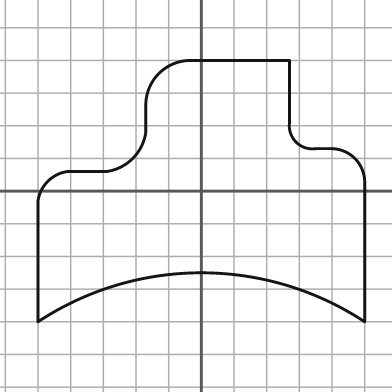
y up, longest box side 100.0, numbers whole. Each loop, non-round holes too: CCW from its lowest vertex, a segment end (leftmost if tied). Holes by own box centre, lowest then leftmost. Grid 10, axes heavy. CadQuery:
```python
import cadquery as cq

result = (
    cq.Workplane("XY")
    .moveTo(-50.0, -40.0)
    .threePointArc((0.0, -25.0), (50.0, -40.0))
    .lineTo(50.0, 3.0)
    .threePointArc((47.0, 10.0), (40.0, 13.0))
    .lineTo(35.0, 13.0)
    .threePointArc((29.0, 15.0), (27.0, 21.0))
    .lineTo(27.0, 40.0)
    .lineTo(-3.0, 40.0)
    .threePointArc((-13.0, 36.0), (-17.0, 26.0))
    .lineTo(-17.0, 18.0)
    .threePointArc((-21.0, 10.0), (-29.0, 6.0))
    .lineTo(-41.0, 6.0)
    .threePointArc((-47.0, 3.0), (-50.0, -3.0))
    .close()
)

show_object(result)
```